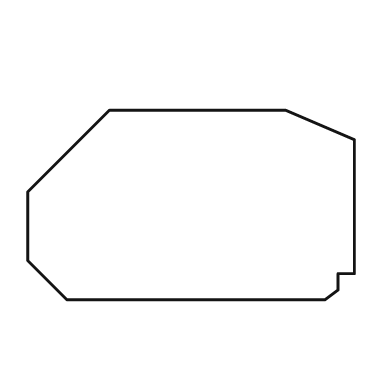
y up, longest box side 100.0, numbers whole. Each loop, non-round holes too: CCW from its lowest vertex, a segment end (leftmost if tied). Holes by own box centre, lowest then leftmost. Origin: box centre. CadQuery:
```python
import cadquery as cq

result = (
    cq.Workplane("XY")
    .moveTo(-38.0, -29.0)
    .lineTo(41.0, -29.0)
    .lineTo(45.0, -26.0)
    .lineTo(45.0, -21.0)
    .lineTo(50.0, -21.0)
    .lineTo(50.0, 20.0)
    .lineTo(29.0, 29.0)
    .lineTo(-25.0, 29.0)
    .lineTo(-50.0, 4.0)
    .lineTo(-50.0, -17.0)
    .close()
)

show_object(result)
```